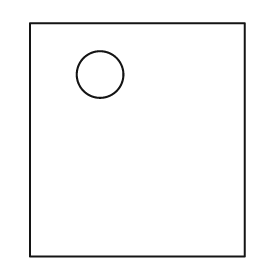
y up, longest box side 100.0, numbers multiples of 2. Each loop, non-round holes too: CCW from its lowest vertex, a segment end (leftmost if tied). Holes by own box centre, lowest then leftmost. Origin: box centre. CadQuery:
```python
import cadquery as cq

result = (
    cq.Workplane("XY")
    .moveTo(-46.0, -50.0)
    .lineTo(46.0, -50.0)
    .lineTo(46.0, 50.0)
    .lineTo(-46.0, 50.0)
    .close()
    .moveTo(-16.0, 28.0)
    .circle(10.0)
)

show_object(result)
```